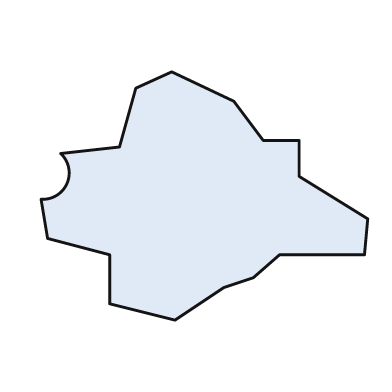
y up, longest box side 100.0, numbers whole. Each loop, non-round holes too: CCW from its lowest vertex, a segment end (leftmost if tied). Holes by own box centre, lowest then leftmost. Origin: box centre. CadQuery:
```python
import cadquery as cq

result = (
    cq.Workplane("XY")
    .moveTo(-9.0, -38.0)
    .lineTo(6.0, -28.0)
    .lineTo(15.0, -25.0)
    .lineTo(23.0, -18.0)
    .lineTo(49.0, -18.0)
    .lineTo(50.0, -7.0)
    .lineTo(29.0, 6.0)
    .lineTo(29.0, 17.0)
    .lineTo(18.0, 17.0)
    .lineTo(9.0, 29.0)
    .lineTo(-10.0, 38.0)
    .lineTo(-21.0, 33.0)
    .lineTo(-26.0, 15.0)
    .lineTo(-44.0, 13.0)
    .threePointArc((-42.0, 4.0), (-50.0, -1.0))
    .lineTo(-48.0, -13.0)
    .lineTo(-29.0, -18.0)
    .lineTo(-29.0, -33.0)
    .close()
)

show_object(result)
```